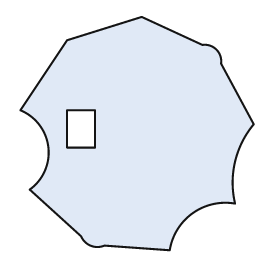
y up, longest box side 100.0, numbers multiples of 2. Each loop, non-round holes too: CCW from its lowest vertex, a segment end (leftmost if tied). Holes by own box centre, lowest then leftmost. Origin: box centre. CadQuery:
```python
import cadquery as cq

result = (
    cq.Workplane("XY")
    .moveTo(14.0, -50.0)
    .threePointArc((24.0, -34.0), (42.0, -30.0))
    .threePointArc((42.0, -12.0), (50.0, 4.0))
    .lineTo(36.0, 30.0)
    .threePointArc((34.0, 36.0), (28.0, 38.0))
    .lineTo(2.0, 50.0)
    .lineTo(-30.0, 40.0)
    .lineTo(-50.0, 10.0)
    .threePointArc((-38.0, -6.0), (-46.0, -24.0))
    .lineTo(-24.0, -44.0)
    .threePointArc((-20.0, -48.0), (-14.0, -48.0))
    .close()
    .moveTo(-30.0, -6.0)
    .lineTo(-18.0, -6.0)
    .lineTo(-18.0, 10.0)
    .lineTo(-30.0, 10.0)
    .close()
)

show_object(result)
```